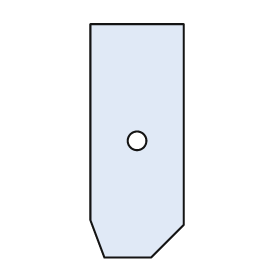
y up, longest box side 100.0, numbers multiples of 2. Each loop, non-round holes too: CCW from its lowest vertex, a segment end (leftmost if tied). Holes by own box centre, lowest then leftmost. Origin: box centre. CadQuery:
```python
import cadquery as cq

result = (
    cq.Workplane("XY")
    .moveTo(-14.0, -50.0)
    .lineTo(6.0, -50.0)
    .lineTo(20.0, -36.0)
    .lineTo(20.0, 50.0)
    .lineTo(-20.0, 50.0)
    .lineTo(-20.0, -34.0)
    .close()
    .moveTo(0.0, 0.0)
    .circle(4.0)
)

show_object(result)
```